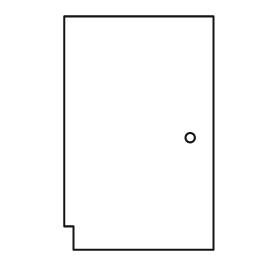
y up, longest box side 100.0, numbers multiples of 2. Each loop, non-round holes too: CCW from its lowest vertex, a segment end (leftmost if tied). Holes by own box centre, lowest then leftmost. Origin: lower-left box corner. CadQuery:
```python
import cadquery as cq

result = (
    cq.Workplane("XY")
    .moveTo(4.0, 0.0)
    .lineTo(64.0, 0.0)
    .lineTo(64.0, 100.0)
    .lineTo(0.0, 100.0)
    .lineTo(0.0, 10.0)
    .lineTo(4.0, 10.0)
    .close()
    .moveTo(54.0, 48.0)
    .circle(2.0)
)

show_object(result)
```